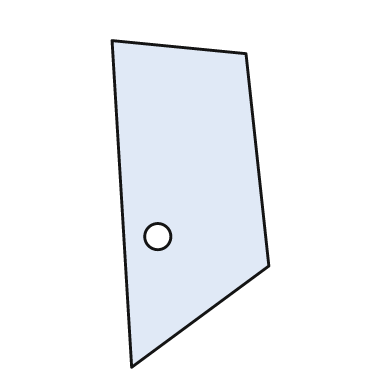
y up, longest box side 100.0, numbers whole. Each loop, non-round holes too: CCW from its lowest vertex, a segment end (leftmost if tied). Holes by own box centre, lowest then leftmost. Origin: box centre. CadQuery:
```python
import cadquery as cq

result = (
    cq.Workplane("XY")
    .moveTo(-18.0, -50.0)
    .lineTo(24.0, -19.0)
    .lineTo(17.0, 46.0)
    .lineTo(-24.0, 50.0)
    .close()
    .moveTo(-10.0, -10.0)
    .circle(4.0)
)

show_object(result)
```